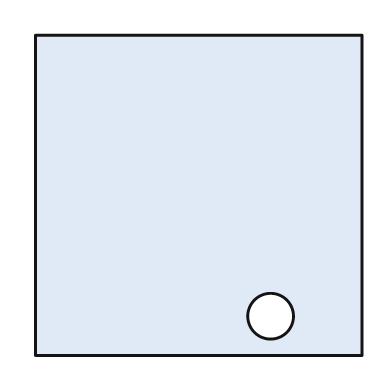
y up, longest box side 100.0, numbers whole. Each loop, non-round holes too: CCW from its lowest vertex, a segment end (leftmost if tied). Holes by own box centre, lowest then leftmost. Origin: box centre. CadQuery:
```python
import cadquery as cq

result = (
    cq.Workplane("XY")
    .moveTo(-50.0, -49.0)
    .lineTo(50.0, -49.0)
    .lineTo(50.0, 49.0)
    .lineTo(-50.0, 49.0)
    .close()
    .moveTo(22.0, -37.0)
    .circle(7.0)
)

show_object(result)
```